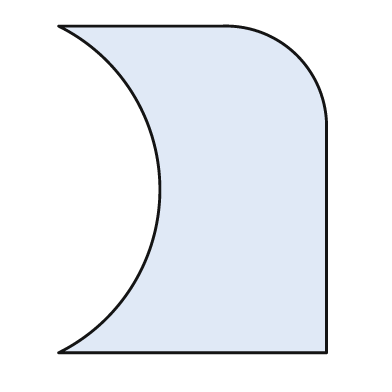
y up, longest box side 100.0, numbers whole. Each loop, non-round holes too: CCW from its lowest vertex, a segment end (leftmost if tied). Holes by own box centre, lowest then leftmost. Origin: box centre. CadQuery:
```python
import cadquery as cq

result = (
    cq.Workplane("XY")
    .moveTo(-41.0, -50.0)
    .lineTo(41.0, -50.0)
    .lineTo(41.0, 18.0)
    .threePointArc((32.0, 41.0), (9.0, 50.0))
    .lineTo(-41.0, 50.0)
    .threePointArc((-10.0, 0.0), (-41.0, -50.0))
    .close()
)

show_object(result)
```